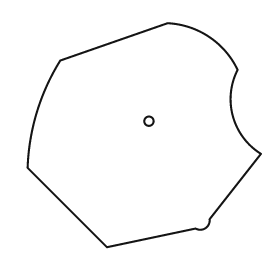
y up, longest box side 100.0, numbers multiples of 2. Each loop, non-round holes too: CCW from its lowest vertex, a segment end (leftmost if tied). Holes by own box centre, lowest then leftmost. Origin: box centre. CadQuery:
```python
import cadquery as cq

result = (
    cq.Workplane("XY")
    .moveTo(-16.0, -48.0)
    .lineTo(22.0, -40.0)
    .threePointArc((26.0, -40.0), (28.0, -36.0))
    .lineTo(50.0, -8.0)
    .threePointArc((38.0, 8.0), (40.0, 28.0))
    .threePointArc((28.0, 42.0), (10.0, 48.0))
    .lineTo(-36.0, 32.0)
    .threePointArc((-46.0, 10.0), (-50.0, -14.0))
    .close()
    .moveTo(2.0, 6.0)
    .circle(2.0)
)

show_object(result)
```